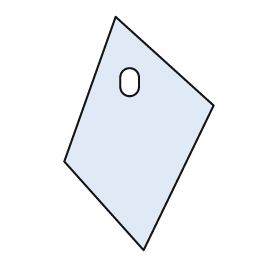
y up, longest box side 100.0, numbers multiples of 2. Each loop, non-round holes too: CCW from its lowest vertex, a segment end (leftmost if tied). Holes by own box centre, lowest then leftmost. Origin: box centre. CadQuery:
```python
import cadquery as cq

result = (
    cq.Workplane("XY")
    .moveTo(2.0, -50.0)
    .lineTo(32.0, 12.0)
    .lineTo(-10.0, 50.0)
    .lineTo(-32.0, -12.0)
    .close()
    .moveTo(-8.0, 20.0)
    .threePointArc((-4.0, 16.0), (0.0, 20.0))
    .lineTo(0.0, 24.0)
    .threePointArc((-4.0, 28.0), (-8.0, 24.0))
    .close()
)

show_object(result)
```